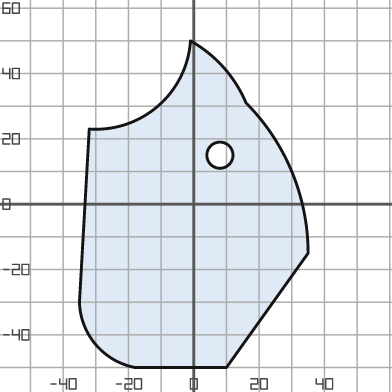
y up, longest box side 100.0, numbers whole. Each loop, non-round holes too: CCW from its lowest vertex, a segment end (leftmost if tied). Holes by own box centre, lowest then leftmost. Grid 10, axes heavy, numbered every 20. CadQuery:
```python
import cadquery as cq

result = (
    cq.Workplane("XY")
    .moveTo(-18.0, -50.0)
    .lineTo(10.0, -50.0)
    .lineTo(35.0, -15.0)
    .threePointArc((30.0, 10.0), (16.0, 31.0))
    .threePointArc((9.0, 42.0), (-1.0, 50.0))
    .threePointArc((-11.0, 30.0), (-32.0, 23.0))
    .lineTo(-35.0, -30.0)
    .threePointArc((-30.0, -43.0), (-18.0, -50.0))
    .close()
    .moveTo(8.0, 15.0)
    .circle(4.0)
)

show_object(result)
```